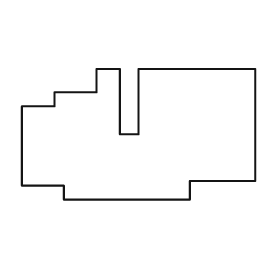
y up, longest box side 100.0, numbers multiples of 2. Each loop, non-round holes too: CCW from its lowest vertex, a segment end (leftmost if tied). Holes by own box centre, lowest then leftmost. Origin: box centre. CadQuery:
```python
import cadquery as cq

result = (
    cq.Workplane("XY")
    .moveTo(-32.0, -28.0)
    .lineTo(22.0, -28.0)
    .lineTo(22.0, -20.0)
    .lineTo(50.0, -20.0)
    .lineTo(50.0, 28.0)
    .lineTo(0.0, 28.0)
    .lineTo(0.0, 0.0)
    .lineTo(-8.0, 0.0)
    .lineTo(-8.0, 28.0)
    .lineTo(-18.0, 28.0)
    .lineTo(-18.0, 18.0)
    .lineTo(-36.0, 18.0)
    .lineTo(-36.0, 12.0)
    .lineTo(-50.0, 12.0)
    .lineTo(-50.0, -22.0)
    .lineTo(-32.0, -22.0)
    .close()
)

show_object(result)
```